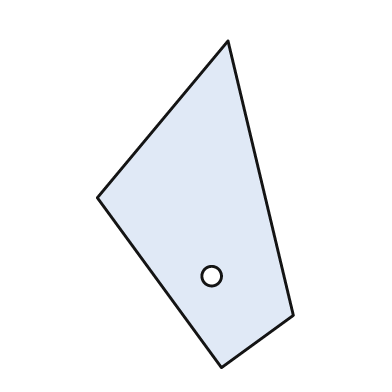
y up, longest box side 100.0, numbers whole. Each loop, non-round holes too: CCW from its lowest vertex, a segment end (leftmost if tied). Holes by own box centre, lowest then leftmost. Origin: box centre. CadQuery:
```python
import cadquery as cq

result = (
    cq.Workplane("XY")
    .moveTo(8.0, -50.0)
    .lineTo(30.0, -34.0)
    .lineTo(10.0, 50.0)
    .lineTo(-30.0, 2.0)
    .close()
    .moveTo(5.0, -22.0)
    .circle(3.0)
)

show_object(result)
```